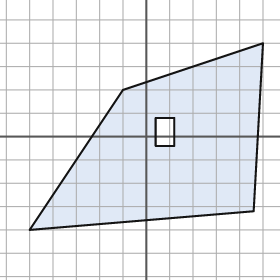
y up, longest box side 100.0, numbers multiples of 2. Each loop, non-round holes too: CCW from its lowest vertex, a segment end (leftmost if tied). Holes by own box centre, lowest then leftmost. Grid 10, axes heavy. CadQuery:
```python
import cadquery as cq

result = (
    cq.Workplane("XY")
    .moveTo(-50.0, -40.0)
    .lineTo(46.0, -32.0)
    .lineTo(50.0, 40.0)
    .lineTo(-10.0, 20.0)
    .close()
    .moveTo(4.0, -4.0)
    .lineTo(12.0, -4.0)
    .lineTo(12.0, 8.0)
    .lineTo(4.0, 8.0)
    .close()
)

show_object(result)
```